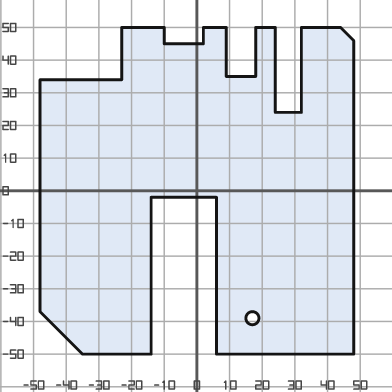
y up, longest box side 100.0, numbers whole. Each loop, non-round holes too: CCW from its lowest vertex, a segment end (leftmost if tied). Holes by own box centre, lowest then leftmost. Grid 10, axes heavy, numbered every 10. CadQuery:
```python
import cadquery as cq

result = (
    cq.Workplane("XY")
    .moveTo(-35.0, -50.0)
    .lineTo(-14.0, -50.0)
    .lineTo(-14.0, -2.0)
    .lineTo(6.0, -2.0)
    .lineTo(6.0, -50.0)
    .lineTo(48.0, -50.0)
    .lineTo(48.0, 46.0)
    .lineTo(44.0, 50.0)
    .lineTo(32.0, 50.0)
    .lineTo(32.0, 24.0)
    .lineTo(24.0, 24.0)
    .lineTo(24.0, 50.0)
    .lineTo(18.0, 50.0)
    .lineTo(18.0, 35.0)
    .lineTo(9.0, 35.0)
    .lineTo(9.0, 50.0)
    .lineTo(2.0, 50.0)
    .lineTo(2.0, 45.0)
    .lineTo(-10.0, 45.0)
    .lineTo(-10.0, 50.0)
    .lineTo(-23.0, 50.0)
    .lineTo(-23.0, 34.0)
    .lineTo(-48.0, 34.0)
    .lineTo(-48.0, -37.0)
    .close()
    .moveTo(17.0, -39.0)
    .circle(2.0)
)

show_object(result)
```